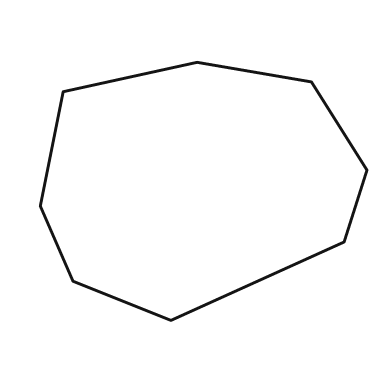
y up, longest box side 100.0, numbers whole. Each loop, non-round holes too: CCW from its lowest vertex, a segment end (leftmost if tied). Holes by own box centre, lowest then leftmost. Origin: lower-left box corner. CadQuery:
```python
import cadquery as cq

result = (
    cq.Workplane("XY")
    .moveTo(40.0, 0.0)
    .lineTo(93.0, 24.0)
    .lineTo(100.0, 46.0)
    .lineTo(83.0, 73.0)
    .lineTo(48.0, 79.0)
    .lineTo(7.0, 70.0)
    .lineTo(0.0, 35.0)
    .lineTo(10.0, 12.0)
    .close()
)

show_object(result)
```